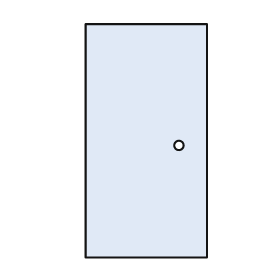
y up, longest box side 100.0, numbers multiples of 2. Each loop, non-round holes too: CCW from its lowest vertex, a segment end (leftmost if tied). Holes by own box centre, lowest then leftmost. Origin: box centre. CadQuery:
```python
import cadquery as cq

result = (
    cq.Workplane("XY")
    .moveTo(-26.0, -50.0)
    .lineTo(26.0, -50.0)
    .lineTo(26.0, 50.0)
    .lineTo(-26.0, 50.0)
    .close()
    .moveTo(14.0, -2.0)
    .circle(2.0)
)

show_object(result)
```